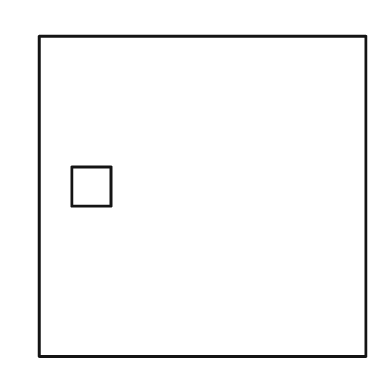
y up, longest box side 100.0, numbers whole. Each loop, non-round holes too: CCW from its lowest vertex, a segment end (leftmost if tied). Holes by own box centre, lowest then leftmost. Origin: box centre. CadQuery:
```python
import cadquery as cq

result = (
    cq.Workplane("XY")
    .moveTo(-50.0, -49.0)
    .lineTo(50.0, -49.0)
    .lineTo(50.0, 49.0)
    .lineTo(-50.0, 49.0)
    .close()
    .moveTo(-40.0, -3.0)
    .lineTo(-28.0, -3.0)
    .lineTo(-28.0, 9.0)
    .lineTo(-40.0, 9.0)
    .close()
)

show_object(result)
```